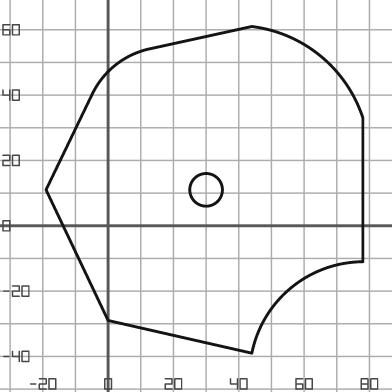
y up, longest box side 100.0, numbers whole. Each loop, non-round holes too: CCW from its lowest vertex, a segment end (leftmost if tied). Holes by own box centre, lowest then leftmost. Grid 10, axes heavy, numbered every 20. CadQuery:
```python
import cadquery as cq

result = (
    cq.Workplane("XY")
    .moveTo(44.0, -39.0)
    .threePointArc((56.0, -19.0), (78.0, -11.0))
    .lineTo(78.0, 33.0)
    .threePointArc((65.0, 52.0), (44.0, 61.0))
    .lineTo(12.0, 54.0)
    .threePointArc((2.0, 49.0), (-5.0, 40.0))
    .lineTo(-19.0, 11.0)
    .lineTo(0.0, -29.0)
    .close()
    .moveTo(30.0, 11.0)
    .circle(5.0)
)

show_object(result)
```